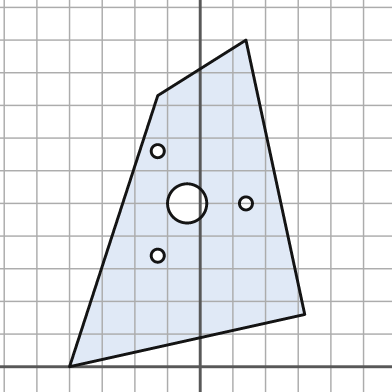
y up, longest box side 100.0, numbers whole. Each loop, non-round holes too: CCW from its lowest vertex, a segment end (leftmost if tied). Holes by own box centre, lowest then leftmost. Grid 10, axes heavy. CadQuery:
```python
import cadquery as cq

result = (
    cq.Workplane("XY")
    .moveTo(-40.0, 0.0)
    .lineTo(32.0, 16.0)
    .lineTo(14.0, 100.0)
    .lineTo(-13.0, 83.0)
    .close()
    .moveTo(-13.0, 34.0)
    .circle(2.0)
    .moveTo(-4.0, 50.0)
    .circle(6.0)
    .moveTo(14.0, 50.0)
    .circle(2.0)
    .moveTo(-13.0, 66.0)
    .circle(2.0)
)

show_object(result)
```